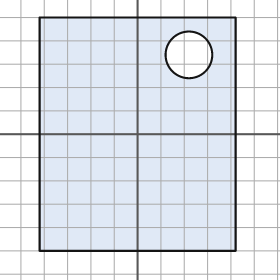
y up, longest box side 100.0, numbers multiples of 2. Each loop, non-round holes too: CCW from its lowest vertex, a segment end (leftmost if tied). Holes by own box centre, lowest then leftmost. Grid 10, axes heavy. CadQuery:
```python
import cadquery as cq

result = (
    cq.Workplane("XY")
    .moveTo(-42.0, -50.0)
    .lineTo(42.0, -50.0)
    .lineTo(42.0, 50.0)
    .lineTo(-42.0, 50.0)
    .close()
    .moveTo(22.0, 34.0)
    .circle(10.0)
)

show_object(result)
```